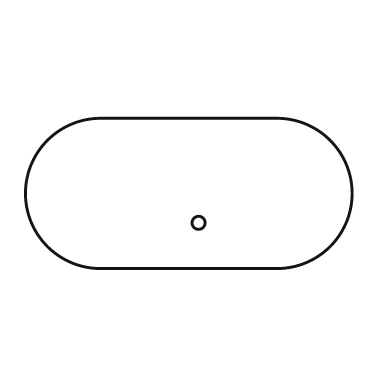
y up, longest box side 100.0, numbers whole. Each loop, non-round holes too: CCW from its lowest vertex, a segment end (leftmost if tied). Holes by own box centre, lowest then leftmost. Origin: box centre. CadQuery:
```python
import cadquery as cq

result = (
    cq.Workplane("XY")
    .moveTo(-27.0, -23.0)
    .lineTo(27.0, -23.0)
    .threePointArc((50.0, 0.0), (27.0, 23.0))
    .lineTo(-27.0, 23.0)
    .threePointArc((-50.0, 0.0), (-27.0, -23.0))
    .close()
    .moveTo(3.0, -9.0)
    .circle(2.0)
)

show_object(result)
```